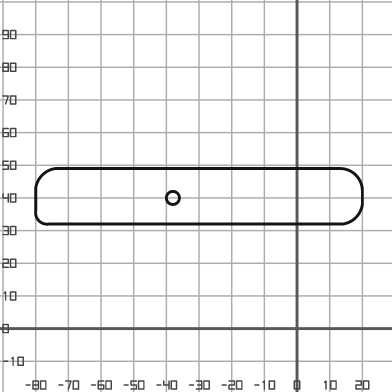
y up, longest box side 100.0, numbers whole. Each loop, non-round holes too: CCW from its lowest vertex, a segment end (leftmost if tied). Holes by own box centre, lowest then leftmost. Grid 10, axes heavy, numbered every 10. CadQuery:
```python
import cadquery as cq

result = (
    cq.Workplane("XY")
    .moveTo(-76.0, 32.0)
    .lineTo(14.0, 32.0)
    .threePointArc((18.0, 34.0), (20.0, 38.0))
    .lineTo(20.0, 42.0)
    .threePointArc((18.0, 47.0), (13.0, 49.0))
    .lineTo(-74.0, 49.0)
    .threePointArc((-78.0, 47.0), (-80.0, 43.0))
    .lineTo(-80.0, 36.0)
    .threePointArc((-79.0, 33.0), (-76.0, 32.0))
    .close()
    .moveTo(-38.0, 40.0)
    .circle(2.0)
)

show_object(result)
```